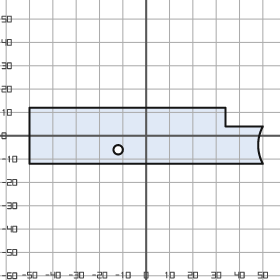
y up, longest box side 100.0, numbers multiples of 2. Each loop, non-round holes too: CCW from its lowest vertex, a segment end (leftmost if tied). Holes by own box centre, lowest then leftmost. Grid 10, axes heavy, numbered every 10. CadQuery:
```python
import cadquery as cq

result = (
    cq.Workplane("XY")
    .moveTo(-50.0, -12.0)
    .lineTo(50.0, -12.0)
    .threePointArc((48.0, -4.0), (50.0, 4.0))
    .lineTo(34.0, 4.0)
    .lineTo(34.0, 12.0)
    .lineTo(-50.0, 12.0)
    .close()
    .moveTo(-12.0, -6.0)
    .circle(2.0)
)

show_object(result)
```